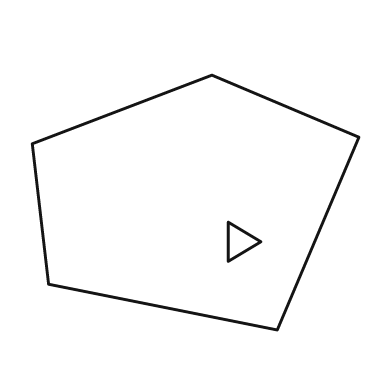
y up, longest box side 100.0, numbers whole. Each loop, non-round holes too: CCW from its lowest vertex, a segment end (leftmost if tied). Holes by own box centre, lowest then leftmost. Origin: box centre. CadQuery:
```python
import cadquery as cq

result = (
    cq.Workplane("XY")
    .moveTo(25.0, -39.0)
    .lineTo(50.0, 20.0)
    .lineTo(5.0, 39.0)
    .lineTo(-50.0, 18.0)
    .lineTo(-45.0, -25.0)
    .close()
    .moveTo(10.0, -18.0)
    .lineTo(20.0, -12.0)
    .lineTo(10.0, -6.0)
    .close()
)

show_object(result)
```